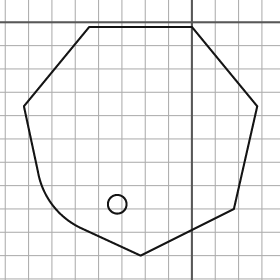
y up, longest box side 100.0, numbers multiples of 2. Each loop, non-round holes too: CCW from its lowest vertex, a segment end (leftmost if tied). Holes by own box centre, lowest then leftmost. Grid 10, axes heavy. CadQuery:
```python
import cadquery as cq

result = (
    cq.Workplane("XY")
    .moveTo(-22.0, -100.0)
    .lineTo(18.0, -80.0)
    .lineTo(28.0, -36.0)
    .lineTo(0.0, -2.0)
    .lineTo(-44.0, -2.0)
    .lineTo(-72.0, -36.0)
    .lineTo(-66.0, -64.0)
    .threePointArc((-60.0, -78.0), (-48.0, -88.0))
    .close()
    .moveTo(-32.0, -78.0)
    .circle(4.0)
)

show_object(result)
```